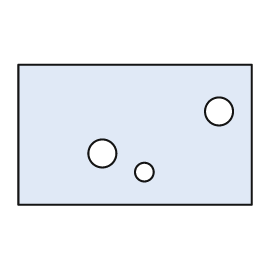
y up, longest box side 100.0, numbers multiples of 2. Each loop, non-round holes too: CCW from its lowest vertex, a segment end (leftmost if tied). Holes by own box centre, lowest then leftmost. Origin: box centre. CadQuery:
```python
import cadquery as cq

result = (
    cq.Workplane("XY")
    .moveTo(-50.0, -30.0)
    .lineTo(50.0, -30.0)
    .lineTo(50.0, 30.0)
    .lineTo(-50.0, 30.0)
    .close()
    .moveTo(4.0, -16.0)
    .circle(4.0)
    .moveTo(-14.0, -8.0)
    .circle(6.0)
    .moveTo(36.0, 10.0)
    .circle(6.0)
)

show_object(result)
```